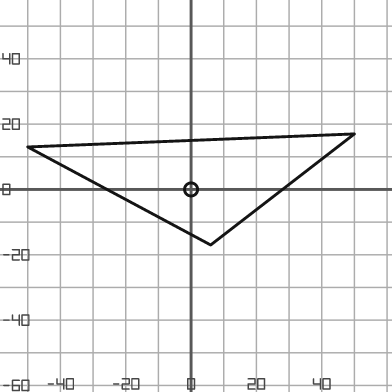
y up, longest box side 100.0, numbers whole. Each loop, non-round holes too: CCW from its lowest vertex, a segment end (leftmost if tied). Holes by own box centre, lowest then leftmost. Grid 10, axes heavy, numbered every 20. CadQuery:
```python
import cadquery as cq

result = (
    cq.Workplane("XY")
    .moveTo(6.0, -17.0)
    .lineTo(50.0, 17.0)
    .lineTo(-50.0, 13.0)
    .close()
    .moveTo(0.0, 0.0)
    .circle(2.0)
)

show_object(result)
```